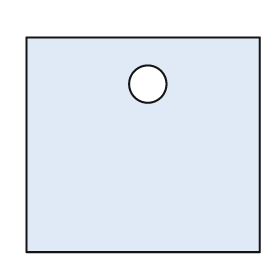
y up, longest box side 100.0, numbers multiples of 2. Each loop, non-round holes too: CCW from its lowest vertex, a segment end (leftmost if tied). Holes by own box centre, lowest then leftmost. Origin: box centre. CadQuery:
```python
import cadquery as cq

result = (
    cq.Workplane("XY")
    .moveTo(-50.0, -46.0)
    .lineTo(50.0, -46.0)
    .lineTo(50.0, 46.0)
    .lineTo(-50.0, 46.0)
    .close()
    .moveTo(2.0, 26.0)
    .circle(8.0)
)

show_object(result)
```